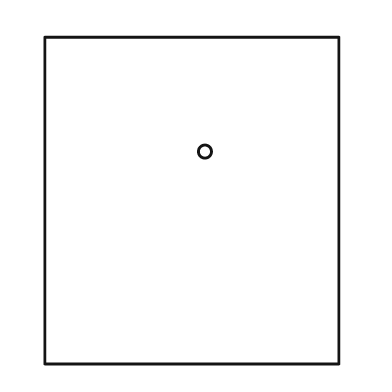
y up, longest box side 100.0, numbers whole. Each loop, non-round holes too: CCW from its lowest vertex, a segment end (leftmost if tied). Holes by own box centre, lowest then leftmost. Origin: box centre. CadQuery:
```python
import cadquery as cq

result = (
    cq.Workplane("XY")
    .moveTo(-45.0, -50.0)
    .lineTo(45.0, -50.0)
    .lineTo(45.0, 50.0)
    .lineTo(-45.0, 50.0)
    .close()
    .moveTo(4.0, 15.0)
    .circle(2.0)
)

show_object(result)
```